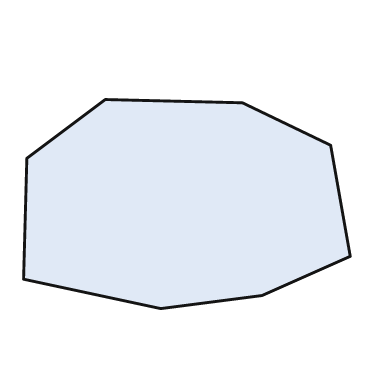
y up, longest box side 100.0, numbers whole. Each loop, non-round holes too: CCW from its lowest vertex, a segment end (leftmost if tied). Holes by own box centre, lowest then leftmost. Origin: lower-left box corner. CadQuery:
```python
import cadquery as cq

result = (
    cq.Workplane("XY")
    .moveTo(42.0, 0.0)
    .lineTo(73.0, 4.0)
    .lineTo(100.0, 16.0)
    .lineTo(94.0, 50.0)
    .lineTo(67.0, 63.0)
    .lineTo(25.0, 64.0)
    .lineTo(1.0, 46.0)
    .lineTo(0.0, 9.0)
    .close()
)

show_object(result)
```